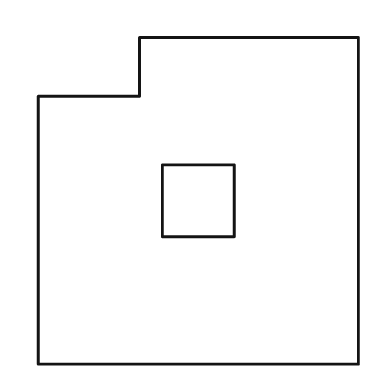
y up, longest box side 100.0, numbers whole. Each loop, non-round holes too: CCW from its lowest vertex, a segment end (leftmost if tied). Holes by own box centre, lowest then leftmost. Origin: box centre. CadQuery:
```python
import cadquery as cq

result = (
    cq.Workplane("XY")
    .moveTo(-49.0, -50.0)
    .lineTo(49.0, -50.0)
    .lineTo(49.0, 50.0)
    .lineTo(-18.0, 50.0)
    .lineTo(-18.0, 32.0)
    .lineTo(-49.0, 32.0)
    .close()
    .moveTo(-11.0, -11.0)
    .lineTo(11.0, -11.0)
    .lineTo(11.0, 11.0)
    .lineTo(-11.0, 11.0)
    .close()
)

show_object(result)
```